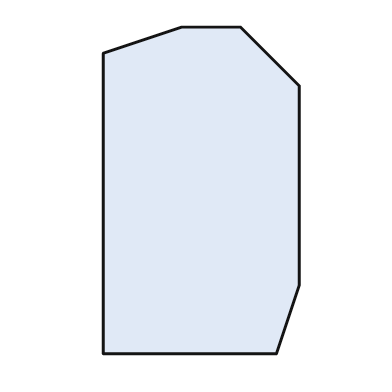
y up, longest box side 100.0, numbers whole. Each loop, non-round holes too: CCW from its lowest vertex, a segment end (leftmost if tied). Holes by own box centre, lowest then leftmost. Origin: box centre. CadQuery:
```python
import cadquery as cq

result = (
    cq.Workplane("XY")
    .moveTo(-30.0, -50.0)
    .lineTo(23.0, -50.0)
    .lineTo(30.0, -29.0)
    .lineTo(30.0, 32.0)
    .lineTo(12.0, 50.0)
    .lineTo(-6.0, 50.0)
    .lineTo(-30.0, 42.0)
    .close()
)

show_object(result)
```